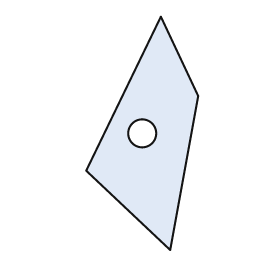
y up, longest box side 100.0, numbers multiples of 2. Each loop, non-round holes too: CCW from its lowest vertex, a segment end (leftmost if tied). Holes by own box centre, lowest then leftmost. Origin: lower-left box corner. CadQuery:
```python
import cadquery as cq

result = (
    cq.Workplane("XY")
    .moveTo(36.0, 0.0)
    .lineTo(48.0, 66.0)
    .lineTo(32.0, 100.0)
    .lineTo(0.0, 34.0)
    .close()
    .moveTo(24.0, 50.0)
    .circle(6.0)
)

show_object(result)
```